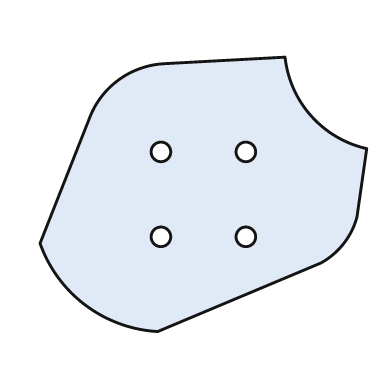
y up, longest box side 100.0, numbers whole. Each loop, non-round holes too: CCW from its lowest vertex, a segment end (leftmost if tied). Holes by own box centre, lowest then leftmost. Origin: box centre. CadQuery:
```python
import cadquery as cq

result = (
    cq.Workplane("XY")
    .moveTo(-14.0, -42.0)
    .lineTo(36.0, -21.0)
    .threePointArc((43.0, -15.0), (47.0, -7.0))
    .lineTo(50.0, 14.0)
    .threePointArc((33.0, 24.0), (25.0, 42.0))
    .lineTo(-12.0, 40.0)
    .threePointArc((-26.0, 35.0), (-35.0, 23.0))
    .lineTo(-50.0, -15.0)
    .threePointArc((-36.0, -34.0), (-14.0, -42.0))
    .close()
    .moveTo(-13.0, -13.0)
    .circle(3.0)
    .moveTo(13.0, -13.0)
    .circle(3.0)
    .moveTo(-13.0, 13.0)
    .circle(3.0)
    .moveTo(13.0, 13.0)
    .circle(3.0)
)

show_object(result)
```